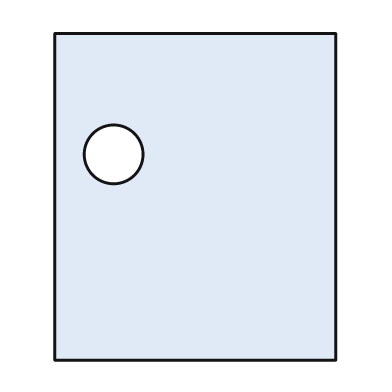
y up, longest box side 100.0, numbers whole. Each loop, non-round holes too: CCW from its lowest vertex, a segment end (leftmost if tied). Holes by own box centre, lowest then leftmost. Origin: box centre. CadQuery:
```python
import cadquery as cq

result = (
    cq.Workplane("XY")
    .moveTo(-43.0, -50.0)
    .lineTo(43.0, -50.0)
    .lineTo(43.0, 50.0)
    .lineTo(-43.0, 50.0)
    .close()
    .moveTo(-25.0, 13.0)
    .circle(9.0)
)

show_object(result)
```